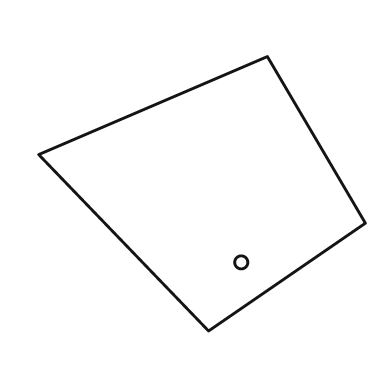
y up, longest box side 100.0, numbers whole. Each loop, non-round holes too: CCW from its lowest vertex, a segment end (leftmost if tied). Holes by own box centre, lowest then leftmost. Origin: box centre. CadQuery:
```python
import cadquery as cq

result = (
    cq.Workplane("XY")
    .moveTo(2.0, -42.0)
    .lineTo(50.0, -9.0)
    .lineTo(20.0, 42.0)
    .lineTo(-50.0, 12.0)
    .close()
    .moveTo(12.0, -21.0)
    .circle(2.0)
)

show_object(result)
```